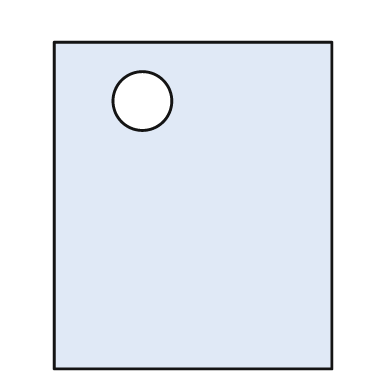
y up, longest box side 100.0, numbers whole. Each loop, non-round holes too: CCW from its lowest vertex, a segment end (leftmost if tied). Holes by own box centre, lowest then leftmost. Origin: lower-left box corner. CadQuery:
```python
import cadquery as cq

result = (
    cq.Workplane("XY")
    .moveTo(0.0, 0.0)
    .lineTo(85.0, 0.0)
    .lineTo(85.0, 100.0)
    .lineTo(0.0, 100.0)
    .close()
    .moveTo(27.0, 82.0)
    .circle(9.0)
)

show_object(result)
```